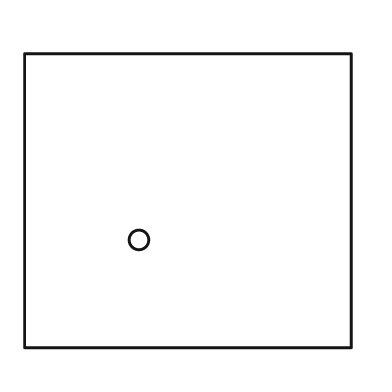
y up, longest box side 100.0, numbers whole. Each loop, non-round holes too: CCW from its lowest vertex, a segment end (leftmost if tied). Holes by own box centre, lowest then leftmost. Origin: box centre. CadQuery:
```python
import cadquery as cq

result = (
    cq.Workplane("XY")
    .moveTo(-50.0, -45.0)
    .lineTo(50.0, -45.0)
    .lineTo(50.0, 45.0)
    .lineTo(-50.0, 45.0)
    .close()
    .moveTo(-15.0, -12.0)
    .circle(3.0)
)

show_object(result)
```